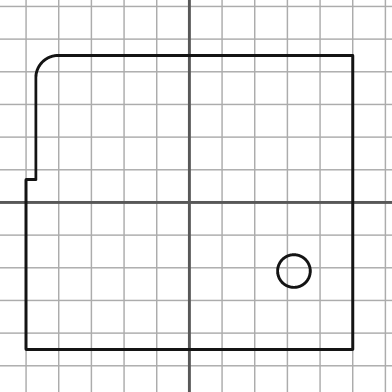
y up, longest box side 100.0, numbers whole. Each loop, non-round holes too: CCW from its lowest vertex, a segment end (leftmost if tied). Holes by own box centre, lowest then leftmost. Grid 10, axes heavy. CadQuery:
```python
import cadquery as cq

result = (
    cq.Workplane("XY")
    .moveTo(-50.0, -45.0)
    .lineTo(50.0, -45.0)
    .lineTo(50.0, 45.0)
    .lineTo(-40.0, 45.0)
    .threePointArc((-45.0, 43.0), (-47.0, 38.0))
    .lineTo(-47.0, 7.0)
    .lineTo(-50.0, 7.0)
    .close()
    .moveTo(32.0, -21.0)
    .circle(5.0)
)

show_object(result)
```